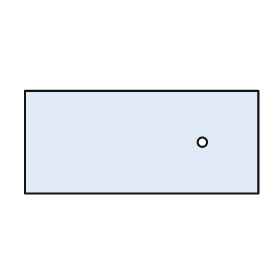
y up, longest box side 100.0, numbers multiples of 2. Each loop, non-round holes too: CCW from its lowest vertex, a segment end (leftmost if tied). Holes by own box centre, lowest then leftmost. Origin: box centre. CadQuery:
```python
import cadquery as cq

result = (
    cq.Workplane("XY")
    .moveTo(-50.0, -22.0)
    .lineTo(50.0, -22.0)
    .lineTo(50.0, 22.0)
    .lineTo(-50.0, 22.0)
    .close()
    .moveTo(26.0, 0.0)
    .circle(2.0)
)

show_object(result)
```